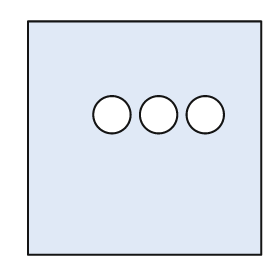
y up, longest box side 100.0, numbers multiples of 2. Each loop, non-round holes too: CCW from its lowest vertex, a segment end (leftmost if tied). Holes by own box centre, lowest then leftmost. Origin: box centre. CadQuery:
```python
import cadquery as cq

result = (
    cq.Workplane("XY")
    .moveTo(-50.0, -50.0)
    .lineTo(50.0, -50.0)
    .lineTo(50.0, 50.0)
    .lineTo(-50.0, 50.0)
    .close()
    .moveTo(-14.0, 10.0)
    .circle(8.0)
    .moveTo(6.0, 10.0)
    .circle(8.0)
    .moveTo(26.0, 10.0)
    .circle(8.0)
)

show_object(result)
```